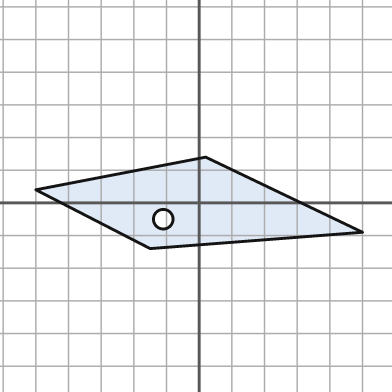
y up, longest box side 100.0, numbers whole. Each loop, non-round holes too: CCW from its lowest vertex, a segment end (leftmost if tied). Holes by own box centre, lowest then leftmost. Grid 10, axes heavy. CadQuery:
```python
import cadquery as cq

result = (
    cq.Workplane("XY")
    .moveTo(-15.0, -14.0)
    .lineTo(50.0, -9.0)
    .lineTo(2.0, 14.0)
    .lineTo(-50.0, 4.0)
    .close()
    .moveTo(-11.0, -5.0)
    .circle(3.0)
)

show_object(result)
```